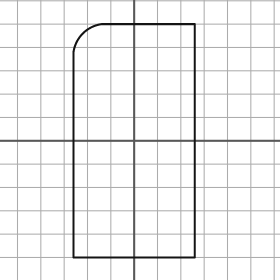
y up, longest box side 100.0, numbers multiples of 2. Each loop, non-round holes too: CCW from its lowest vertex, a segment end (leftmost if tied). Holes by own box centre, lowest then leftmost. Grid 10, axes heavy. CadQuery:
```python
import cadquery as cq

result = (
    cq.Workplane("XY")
    .moveTo(-26.0, -50.0)
    .lineTo(26.0, -50.0)
    .lineTo(26.0, 50.0)
    .lineTo(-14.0, 50.0)
    .threePointArc((-22.0, 46.0), (-26.0, 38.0))
    .close()
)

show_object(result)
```